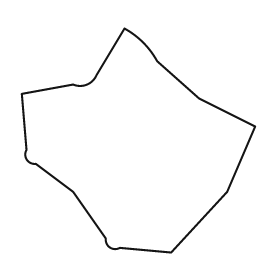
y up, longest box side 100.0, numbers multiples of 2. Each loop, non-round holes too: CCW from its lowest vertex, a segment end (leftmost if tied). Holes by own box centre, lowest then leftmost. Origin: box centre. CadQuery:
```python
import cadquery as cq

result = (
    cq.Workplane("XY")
    .moveTo(14.0, -48.0)
    .lineTo(38.0, -22.0)
    .lineTo(50.0, 6.0)
    .lineTo(26.0, 18.0)
    .lineTo(8.0, 34.0)
    .threePointArc((2.0, 42.0), (-6.0, 48.0))
    .lineTo(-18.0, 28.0)
    .threePointArc((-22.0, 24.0), (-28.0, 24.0))
    .lineTo(-50.0, 20.0)
    .lineTo(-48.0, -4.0)
    .threePointArc((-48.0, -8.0), (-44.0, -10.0))
    .lineTo(-28.0, -22.0)
    .lineTo(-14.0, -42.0)
    .threePointArc((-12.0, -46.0), (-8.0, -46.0))
    .close()
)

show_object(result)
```